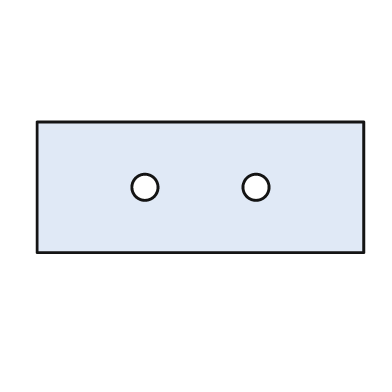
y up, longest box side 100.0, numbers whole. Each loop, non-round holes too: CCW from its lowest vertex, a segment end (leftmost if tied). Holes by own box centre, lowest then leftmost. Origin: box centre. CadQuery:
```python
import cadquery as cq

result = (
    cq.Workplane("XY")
    .moveTo(-50.0, -20.0)
    .lineTo(50.0, -20.0)
    .lineTo(50.0, 20.0)
    .lineTo(-50.0, 20.0)
    .close()
    .moveTo(-17.0, 0.0)
    .circle(4.0)
    .moveTo(17.0, 0.0)
    .circle(4.0)
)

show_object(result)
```